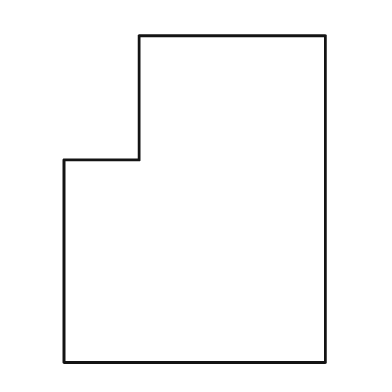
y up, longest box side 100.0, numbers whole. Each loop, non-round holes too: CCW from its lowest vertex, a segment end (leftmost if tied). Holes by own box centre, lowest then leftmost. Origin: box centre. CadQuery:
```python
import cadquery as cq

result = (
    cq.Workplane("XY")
    .moveTo(-40.0, -50.0)
    .lineTo(40.0, -50.0)
    .lineTo(40.0, 50.0)
    .lineTo(-17.0, 50.0)
    .lineTo(-17.0, 12.0)
    .lineTo(-40.0, 12.0)
    .close()
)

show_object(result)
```